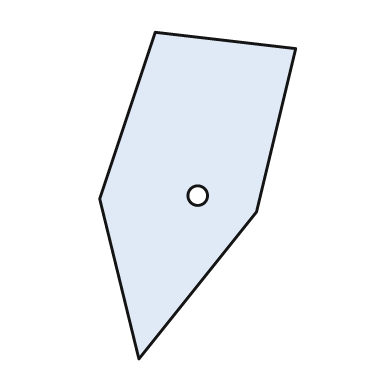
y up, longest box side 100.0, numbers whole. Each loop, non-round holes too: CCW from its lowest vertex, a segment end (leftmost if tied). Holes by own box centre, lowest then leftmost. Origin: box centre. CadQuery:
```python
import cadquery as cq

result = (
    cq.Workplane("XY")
    .moveTo(-18.0, -50.0)
    .lineTo(18.0, -5.0)
    .lineTo(30.0, 45.0)
    .lineTo(-13.0, 50.0)
    .lineTo(-30.0, -1.0)
    .close()
    .moveTo(0.0, 0.0)
    .circle(3.0)
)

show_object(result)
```